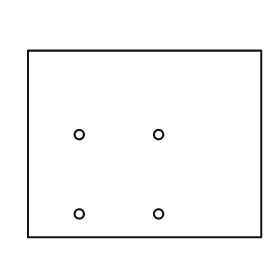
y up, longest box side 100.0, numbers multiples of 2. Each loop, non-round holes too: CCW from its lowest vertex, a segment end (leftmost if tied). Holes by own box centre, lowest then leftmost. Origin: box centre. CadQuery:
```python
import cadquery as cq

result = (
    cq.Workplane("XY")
    .moveTo(-50.0, -40.0)
    .lineTo(50.0, -40.0)
    .lineTo(50.0, 40.0)
    .lineTo(-50.0, 40.0)
    .close()
    .moveTo(-28.0, -30.0)
    .circle(2.0)
    .moveTo(6.0, -30.0)
    .circle(2.0)
    .moveTo(-28.0, 4.0)
    .circle(2.0)
    .moveTo(6.0, 4.0)
    .circle(2.0)
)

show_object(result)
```